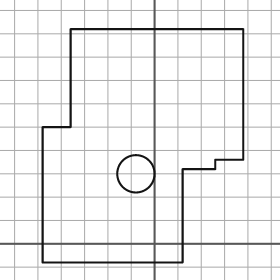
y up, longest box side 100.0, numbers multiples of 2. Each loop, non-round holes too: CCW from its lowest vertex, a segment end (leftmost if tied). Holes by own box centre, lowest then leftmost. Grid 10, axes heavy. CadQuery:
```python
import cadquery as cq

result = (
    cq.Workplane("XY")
    .moveTo(-48.0, -8.0)
    .lineTo(12.0, -8.0)
    .lineTo(12.0, 32.0)
    .lineTo(26.0, 32.0)
    .lineTo(26.0, 36.0)
    .lineTo(38.0, 36.0)
    .lineTo(38.0, 92.0)
    .lineTo(-36.0, 92.0)
    .lineTo(-36.0, 50.0)
    .lineTo(-48.0, 50.0)
    .close()
    .moveTo(-8.0, 30.0)
    .circle(8.0)
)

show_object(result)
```